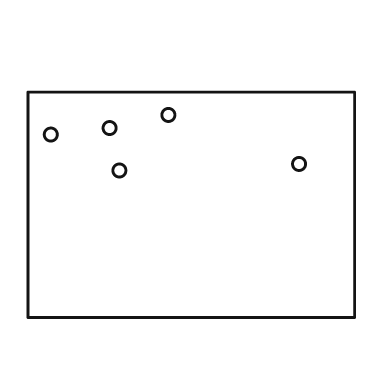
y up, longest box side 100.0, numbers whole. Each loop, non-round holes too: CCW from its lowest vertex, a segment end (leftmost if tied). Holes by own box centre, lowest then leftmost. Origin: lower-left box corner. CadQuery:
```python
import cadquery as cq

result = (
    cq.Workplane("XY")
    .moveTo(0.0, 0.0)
    .lineTo(100.0, 0.0)
    .lineTo(100.0, 69.0)
    .lineTo(0.0, 69.0)
    .close()
    .moveTo(28.0, 45.0)
    .circle(2.0)
    .moveTo(83.0, 47.0)
    .circle(2.0)
    .moveTo(7.0, 56.0)
    .circle(2.0)
    .moveTo(25.0, 58.0)
    .circle(2.0)
    .moveTo(43.0, 62.0)
    .circle(2.0)
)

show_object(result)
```